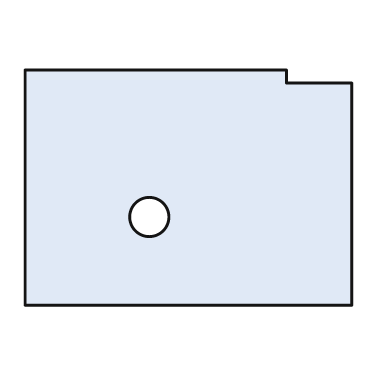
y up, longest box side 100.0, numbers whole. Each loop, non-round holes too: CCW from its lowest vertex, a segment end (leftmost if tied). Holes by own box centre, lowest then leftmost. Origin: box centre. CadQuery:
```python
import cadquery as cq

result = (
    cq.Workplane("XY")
    .moveTo(-50.0, -36.0)
    .lineTo(50.0, -36.0)
    .lineTo(50.0, 32.0)
    .lineTo(30.0, 32.0)
    .lineTo(30.0, 36.0)
    .lineTo(-50.0, 36.0)
    .close()
    .moveTo(-12.0, -9.0)
    .circle(6.0)
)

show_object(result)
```